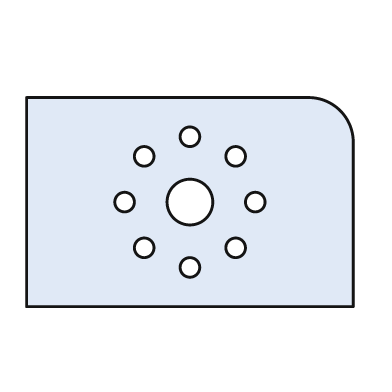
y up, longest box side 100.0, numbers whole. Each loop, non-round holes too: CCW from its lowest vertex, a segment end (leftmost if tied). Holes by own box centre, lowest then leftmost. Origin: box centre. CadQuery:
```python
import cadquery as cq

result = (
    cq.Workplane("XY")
    .moveTo(-50.0, -32.0)
    .lineTo(50.0, -32.0)
    .lineTo(50.0, 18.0)
    .threePointArc((46.0, 28.0), (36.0, 32.0))
    .lineTo(-50.0, 32.0)
    .close()
    .moveTo(0.0, -20.0)
    .circle(3.0)
    .moveTo(-14.0, -14.0)
    .circle(3.0)
    .moveTo(14.0, -14.0)
    .circle(3.0)
    .moveTo(-20.0, 0.0)
    .circle(3.0)
    .moveTo(0.0, 0.0)
    .circle(7.0)
    .moveTo(20.0, 0.0)
    .circle(3.0)
    .moveTo(-14.0, 14.0)
    .circle(3.0)
    .moveTo(14.0, 14.0)
    .circle(3.0)
    .moveTo(0.0, 20.0)
    .circle(3.0)
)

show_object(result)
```